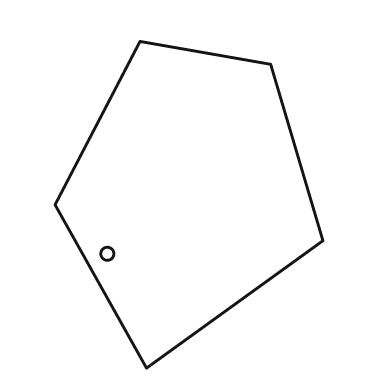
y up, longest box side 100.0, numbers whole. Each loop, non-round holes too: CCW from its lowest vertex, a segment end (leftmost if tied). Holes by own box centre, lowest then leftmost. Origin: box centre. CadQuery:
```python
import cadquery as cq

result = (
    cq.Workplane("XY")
    .moveTo(-13.0, -50.0)
    .lineTo(41.0, -11.0)
    .lineTo(25.0, 43.0)
    .lineTo(-15.0, 50.0)
    .lineTo(-41.0, 0.0)
    .close()
    .moveTo(-25.0, -15.0)
    .circle(2.0)
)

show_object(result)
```